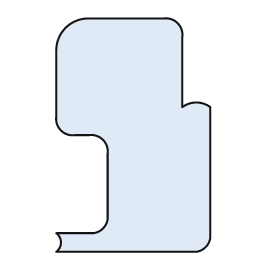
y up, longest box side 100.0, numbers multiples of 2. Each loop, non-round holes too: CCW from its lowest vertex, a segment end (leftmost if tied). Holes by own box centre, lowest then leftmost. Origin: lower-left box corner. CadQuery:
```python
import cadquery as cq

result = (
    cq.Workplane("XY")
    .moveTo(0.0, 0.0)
    .lineTo(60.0, 0.0)
    .threePointArc((64.0, 2.0), (66.0, 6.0))
    .lineTo(66.0, 62.0)
    .threePointArc((60.0, 64.0), (54.0, 62.0))
    .lineTo(54.0, 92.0)
    .threePointArc((52.0, 98.0), (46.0, 100.0))
    .lineTo(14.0, 100.0)
    .threePointArc((4.0, 96.0), (0.0, 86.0))
    .lineTo(0.0, 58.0)
    .threePointArc((2.0, 52.0), (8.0, 50.0))
    .lineTo(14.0, 50.0)
    .threePointArc((20.0, 48.0), (22.0, 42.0))
    .lineTo(22.0, 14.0)
    .threePointArc((20.0, 10.0), (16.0, 8.0))
    .lineTo(0.0, 8.0)
    .threePointArc((2.0, 4.0), (0.0, 0.0))
    .close()
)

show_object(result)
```